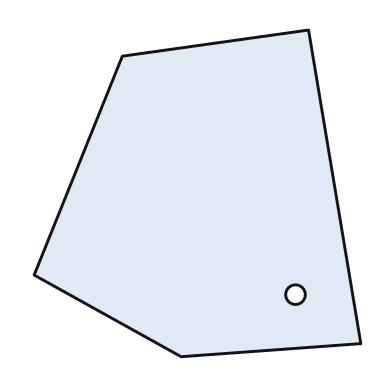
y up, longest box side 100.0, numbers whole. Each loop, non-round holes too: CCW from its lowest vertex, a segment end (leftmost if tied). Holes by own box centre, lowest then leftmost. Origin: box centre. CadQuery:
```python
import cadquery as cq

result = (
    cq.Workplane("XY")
    .moveTo(-5.0, -50.0)
    .lineTo(50.0, -46.0)
    .lineTo(34.0, 50.0)
    .lineTo(-23.0, 42.0)
    .lineTo(-50.0, -25.0)
    .close()
    .moveTo(30.0, -31.0)
    .circle(3.0)
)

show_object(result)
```